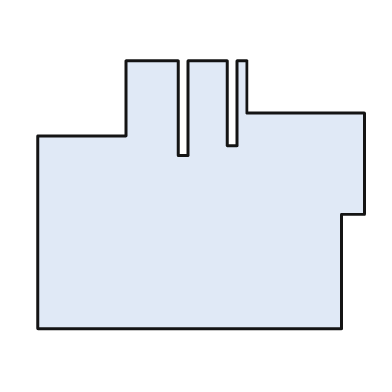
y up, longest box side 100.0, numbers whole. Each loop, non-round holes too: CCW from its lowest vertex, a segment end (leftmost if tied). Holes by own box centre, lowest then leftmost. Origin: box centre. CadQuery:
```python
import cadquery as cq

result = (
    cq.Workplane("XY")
    .moveTo(-50.0, -41.0)
    .lineTo(43.0, -41.0)
    .lineTo(43.0, -6.0)
    .lineTo(50.0, -6.0)
    .lineTo(50.0, 25.0)
    .lineTo(14.0, 25.0)
    .lineTo(14.0, 41.0)
    .lineTo(11.0, 41.0)
    .lineTo(11.0, 15.0)
    .lineTo(8.0, 15.0)
    .lineTo(8.0, 41.0)
    .lineTo(-4.0, 41.0)
    .lineTo(-4.0, 12.0)
    .lineTo(-7.0, 12.0)
    .lineTo(-7.0, 41.0)
    .lineTo(-23.0, 41.0)
    .lineTo(-23.0, 18.0)
    .lineTo(-50.0, 18.0)
    .close()
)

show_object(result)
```